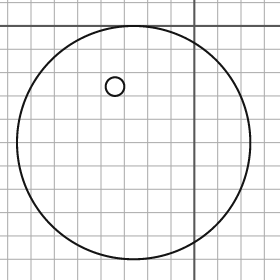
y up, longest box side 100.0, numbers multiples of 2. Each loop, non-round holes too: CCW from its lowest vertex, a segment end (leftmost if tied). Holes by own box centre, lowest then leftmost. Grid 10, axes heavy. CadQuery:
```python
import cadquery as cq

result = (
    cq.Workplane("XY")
    .moveTo(-26.0, -50.0)
    .circle(50.0)
    .moveTo(-34.0, -26.0)
    .circle(4.0)
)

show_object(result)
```